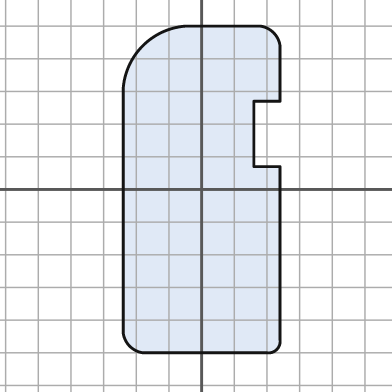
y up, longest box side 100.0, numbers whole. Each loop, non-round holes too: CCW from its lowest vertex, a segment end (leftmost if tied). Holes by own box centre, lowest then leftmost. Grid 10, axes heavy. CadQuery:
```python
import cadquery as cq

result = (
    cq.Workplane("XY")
    .moveTo(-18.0, -50.0)
    .lineTo(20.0, -50.0)
    .threePointArc((23.0, -49.0), (24.0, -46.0))
    .lineTo(24.0, 7.0)
    .lineTo(16.0, 7.0)
    .lineTo(16.0, 27.0)
    .lineTo(24.0, 27.0)
    .lineTo(24.0, 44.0)
    .threePointArc((22.0, 48.0), (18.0, 50.0))
    .lineTo(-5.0, 50.0)
    .threePointArc((-18.0, 44.0), (-24.0, 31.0))
    .lineTo(-24.0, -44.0)
    .threePointArc((-22.0, -48.0), (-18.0, -50.0))
    .close()
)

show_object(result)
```